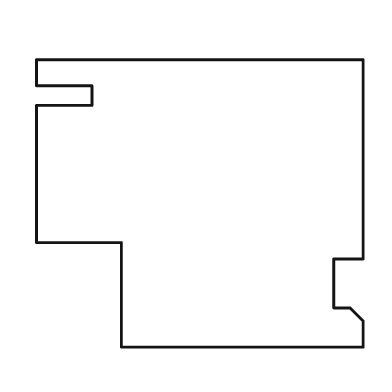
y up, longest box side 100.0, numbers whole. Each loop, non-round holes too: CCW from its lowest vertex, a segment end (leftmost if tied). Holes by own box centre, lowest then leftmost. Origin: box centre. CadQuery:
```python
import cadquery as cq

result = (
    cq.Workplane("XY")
    .moveTo(-24.0, -44.0)
    .lineTo(50.0, -44.0)
    .lineTo(50.0, -36.0)
    .lineTo(46.0, -32.0)
    .lineTo(41.0, -32.0)
    .lineTo(41.0, -17.0)
    .lineTo(50.0, -17.0)
    .lineTo(50.0, 44.0)
    .lineTo(-50.0, 44.0)
    .lineTo(-50.0, 36.0)
    .lineTo(-33.0, 36.0)
    .lineTo(-33.0, 30.0)
    .lineTo(-50.0, 30.0)
    .lineTo(-50.0, -12.0)
    .lineTo(-24.0, -12.0)
    .close()
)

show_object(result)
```